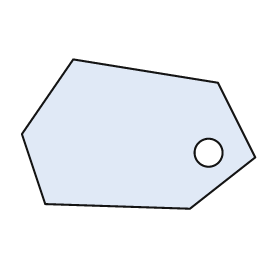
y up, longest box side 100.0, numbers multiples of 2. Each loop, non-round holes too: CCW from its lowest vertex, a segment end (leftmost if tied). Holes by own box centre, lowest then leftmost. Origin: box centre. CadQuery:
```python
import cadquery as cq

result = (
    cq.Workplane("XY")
    .moveTo(22.0, -32.0)
    .lineTo(50.0, -10.0)
    .lineTo(34.0, 22.0)
    .lineTo(-28.0, 32.0)
    .lineTo(-50.0, 0.0)
    .lineTo(-40.0, -30.0)
    .close()
    .moveTo(30.0, -8.0)
    .circle(6.0)
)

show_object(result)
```